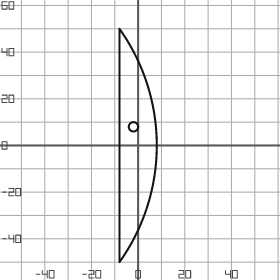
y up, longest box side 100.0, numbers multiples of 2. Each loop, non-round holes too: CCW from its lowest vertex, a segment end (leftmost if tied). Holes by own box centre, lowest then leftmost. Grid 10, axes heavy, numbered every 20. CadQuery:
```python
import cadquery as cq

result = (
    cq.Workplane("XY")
    .moveTo(-8.0, -50.0)
    .threePointArc((8.0, 0.0), (-8.0, 50.0))
    .close()
    .moveTo(-2.0, 8.0)
    .circle(2.0)
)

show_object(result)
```